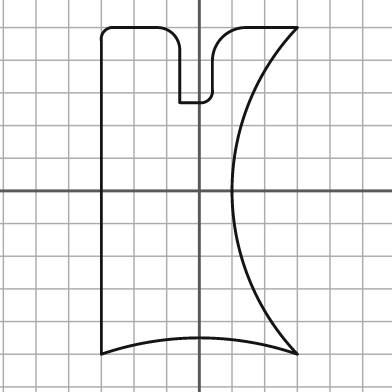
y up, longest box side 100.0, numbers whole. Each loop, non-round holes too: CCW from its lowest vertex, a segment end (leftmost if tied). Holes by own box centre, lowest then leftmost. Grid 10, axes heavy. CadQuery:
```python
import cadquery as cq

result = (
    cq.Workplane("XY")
    .moveTo(-30.0, -50.0)
    .threePointArc((0.0, -45.0), (30.0, -50.0))
    .threePointArc((10.0, 0.0), (30.0, 50.0))
    .lineTo(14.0, 50.0)
    .threePointArc((7.0, 47.0), (4.0, 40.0))
    .lineTo(4.0, 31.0)
    .threePointArc((3.0, 28.0), (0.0, 27.0))
    .lineTo(-6.0, 27.0)
    .lineTo(-6.0, 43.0)
    .threePointArc((-8.0, 48.0), (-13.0, 50.0))
    .lineTo(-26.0, 50.0)
    .threePointArc((-29.0, 49.0), (-30.0, 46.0))
    .close()
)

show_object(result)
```